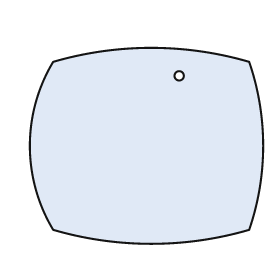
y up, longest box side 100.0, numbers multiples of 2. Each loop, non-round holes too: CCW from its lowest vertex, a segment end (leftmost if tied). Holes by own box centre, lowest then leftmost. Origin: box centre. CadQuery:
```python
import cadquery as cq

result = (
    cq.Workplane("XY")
    .moveTo(-40.0, -36.0)
    .threePointArc((2.0, -42.0), (44.0, -36.0))
    .threePointArc((50.0, 0.0), (44.0, 36.0))
    .threePointArc((2.0, 42.0), (-40.0, 36.0))
    .threePointArc((-50.0, 0.0), (-40.0, -36.0))
    .close()
    .moveTo(14.0, 30.0)
    .circle(2.0)
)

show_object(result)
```